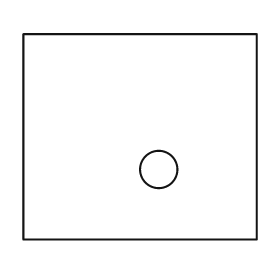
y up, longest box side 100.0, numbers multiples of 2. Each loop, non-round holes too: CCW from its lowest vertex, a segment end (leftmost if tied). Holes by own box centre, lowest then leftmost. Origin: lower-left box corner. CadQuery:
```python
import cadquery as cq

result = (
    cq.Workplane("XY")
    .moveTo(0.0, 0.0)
    .lineTo(100.0, 0.0)
    .lineTo(100.0, 88.0)
    .lineTo(0.0, 88.0)
    .close()
    .moveTo(58.0, 30.0)
    .circle(8.0)
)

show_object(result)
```